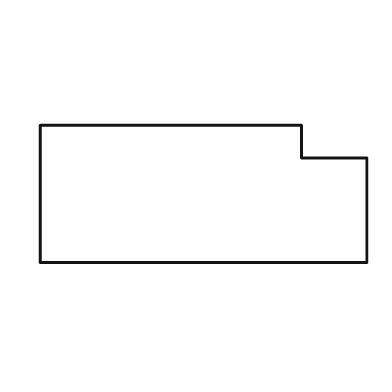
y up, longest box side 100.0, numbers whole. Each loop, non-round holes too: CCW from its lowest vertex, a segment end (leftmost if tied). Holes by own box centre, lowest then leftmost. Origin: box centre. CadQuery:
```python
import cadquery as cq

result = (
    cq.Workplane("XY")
    .moveTo(-50.0, -21.0)
    .lineTo(50.0, -21.0)
    .lineTo(50.0, 11.0)
    .lineTo(30.0, 11.0)
    .lineTo(30.0, 21.0)
    .lineTo(-50.0, 21.0)
    .close()
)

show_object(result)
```